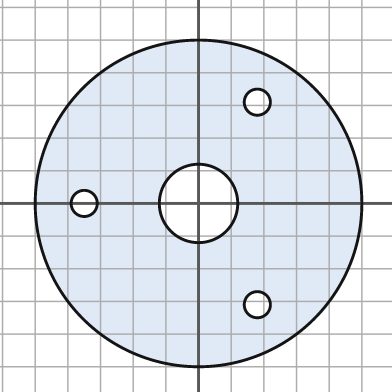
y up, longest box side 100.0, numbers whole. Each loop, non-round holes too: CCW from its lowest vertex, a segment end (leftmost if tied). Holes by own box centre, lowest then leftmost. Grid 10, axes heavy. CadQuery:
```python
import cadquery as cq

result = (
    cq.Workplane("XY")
    .moveTo(0.0, 0.0)
    .circle(50.0)
    .moveTo(18.0, -31.0)
    .circle(4.0)
    .moveTo(-35.0, 0.0)
    .circle(4.0)
    .moveTo(0.0, 0.0)
    .circle(12.0)
    .moveTo(18.0, 31.0)
    .circle(4.0)
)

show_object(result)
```